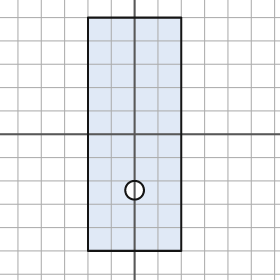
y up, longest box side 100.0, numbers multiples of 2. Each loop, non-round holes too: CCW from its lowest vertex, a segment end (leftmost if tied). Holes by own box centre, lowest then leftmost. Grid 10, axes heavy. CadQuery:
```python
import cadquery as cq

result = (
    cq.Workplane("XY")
    .moveTo(-20.0, -50.0)
    .lineTo(20.0, -50.0)
    .lineTo(20.0, 50.0)
    .lineTo(-20.0, 50.0)
    .close()
    .moveTo(0.0, -24.0)
    .circle(4.0)
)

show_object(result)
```